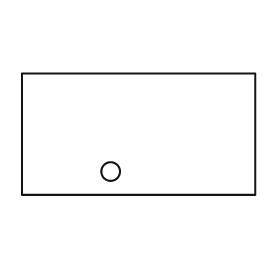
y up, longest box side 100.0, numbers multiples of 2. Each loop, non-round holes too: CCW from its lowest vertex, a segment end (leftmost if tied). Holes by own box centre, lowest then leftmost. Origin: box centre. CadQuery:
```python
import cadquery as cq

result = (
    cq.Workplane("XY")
    .moveTo(-50.0, -26.0)
    .lineTo(50.0, -26.0)
    .lineTo(50.0, 26.0)
    .lineTo(-50.0, 26.0)
    .close()
    .moveTo(-12.0, -16.0)
    .circle(4.0)
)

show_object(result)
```